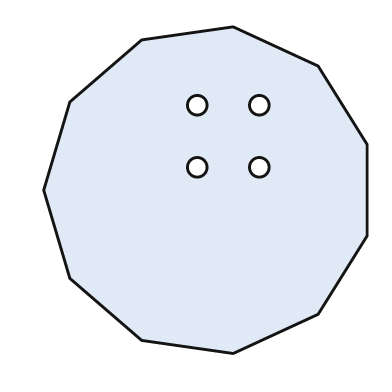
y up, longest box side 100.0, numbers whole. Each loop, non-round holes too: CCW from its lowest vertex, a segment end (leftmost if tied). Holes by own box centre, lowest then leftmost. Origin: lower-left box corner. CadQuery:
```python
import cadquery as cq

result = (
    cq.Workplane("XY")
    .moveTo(58.0, 0.0)
    .lineTo(84.0, 12.0)
    .lineTo(99.0, 36.0)
    .lineTo(99.0, 64.0)
    .lineTo(84.0, 88.0)
    .lineTo(58.0, 100.0)
    .lineTo(30.0, 96.0)
    .lineTo(8.0, 77.0)
    .lineTo(0.0, 50.0)
    .lineTo(8.0, 23.0)
    .lineTo(30.0, 4.0)
    .close()
    .moveTo(47.0, 57.0)
    .circle(3.0)
    .moveTo(66.0, 57.0)
    .circle(3.0)
    .moveTo(47.0, 76.0)
    .circle(3.0)
    .moveTo(66.0, 76.0)
    .circle(3.0)
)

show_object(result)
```